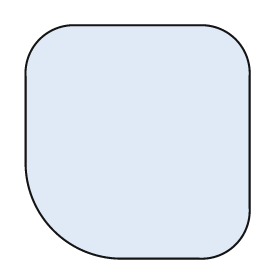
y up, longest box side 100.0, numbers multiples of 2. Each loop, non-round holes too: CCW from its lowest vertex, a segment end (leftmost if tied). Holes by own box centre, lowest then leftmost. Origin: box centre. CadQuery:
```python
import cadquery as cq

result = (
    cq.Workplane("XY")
    .moveTo(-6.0, -50.0)
    .lineTo(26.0, -50.0)
    .threePointArc((42.0, -44.0), (48.0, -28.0))
    .lineTo(48.0, 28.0)
    .threePointArc((42.0, 44.0), (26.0, 50.0))
    .lineTo(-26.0, 50.0)
    .threePointArc((-42.0, 44.0), (-48.0, 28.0))
    .lineTo(-48.0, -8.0)
    .threePointArc((-36.0, -38.0), (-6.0, -50.0))
    .close()
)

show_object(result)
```